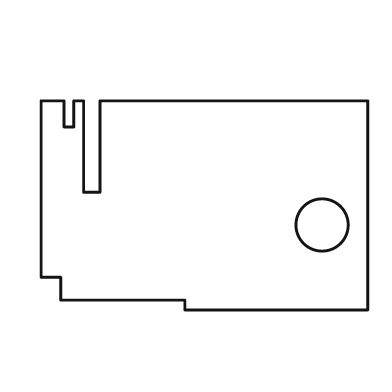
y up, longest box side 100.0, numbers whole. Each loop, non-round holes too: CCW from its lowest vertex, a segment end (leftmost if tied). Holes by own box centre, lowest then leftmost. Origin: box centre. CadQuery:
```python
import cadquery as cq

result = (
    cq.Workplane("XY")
    .moveTo(-6.0, -32.0)
    .lineTo(50.0, -32.0)
    .lineTo(50.0, 32.0)
    .lineTo(-32.0, 32.0)
    .lineTo(-32.0, 4.0)
    .lineTo(-37.0, 4.0)
    .lineTo(-37.0, 32.0)
    .lineTo(-40.0, 32.0)
    .lineTo(-40.0, 24.0)
    .lineTo(-43.0, 24.0)
    .lineTo(-43.0, 32.0)
    .lineTo(-50.0, 32.0)
    .lineTo(-50.0, -22.0)
    .lineTo(-44.0, -22.0)
    .lineTo(-44.0, -29.0)
    .lineTo(-6.0, -29.0)
    .close()
    .moveTo(36.0, -6.0)
    .circle(8.0)
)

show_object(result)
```